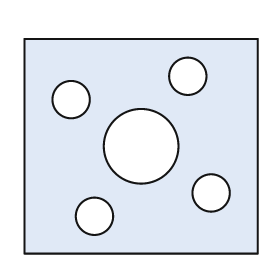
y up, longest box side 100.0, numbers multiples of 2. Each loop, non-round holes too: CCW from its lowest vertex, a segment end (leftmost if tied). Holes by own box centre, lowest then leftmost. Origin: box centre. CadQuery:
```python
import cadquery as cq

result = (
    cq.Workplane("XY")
    .moveTo(-50.0, -46.0)
    .lineTo(50.0, -46.0)
    .lineTo(50.0, 46.0)
    .lineTo(-50.0, 46.0)
    .close()
    .moveTo(-20.0, -30.0)
    .circle(8.0)
    .moveTo(30.0, -20.0)
    .circle(8.0)
    .moveTo(0.0, 0.0)
    .circle(16.0)
    .moveTo(-30.0, 20.0)
    .circle(8.0)
    .moveTo(20.0, 30.0)
    .circle(8.0)
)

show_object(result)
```